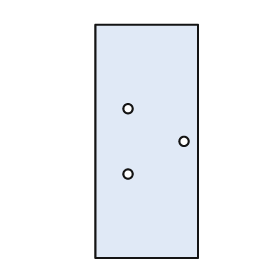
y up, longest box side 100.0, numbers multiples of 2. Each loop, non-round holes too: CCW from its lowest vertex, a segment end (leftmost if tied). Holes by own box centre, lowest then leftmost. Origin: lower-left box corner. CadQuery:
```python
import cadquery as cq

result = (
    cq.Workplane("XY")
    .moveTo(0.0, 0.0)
    .lineTo(44.0, 0.0)
    .lineTo(44.0, 100.0)
    .lineTo(0.0, 100.0)
    .close()
    .moveTo(14.0, 36.0)
    .circle(2.0)
    .moveTo(38.0, 50.0)
    .circle(2.0)
    .moveTo(14.0, 64.0)
    .circle(2.0)
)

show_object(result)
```